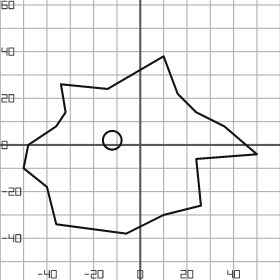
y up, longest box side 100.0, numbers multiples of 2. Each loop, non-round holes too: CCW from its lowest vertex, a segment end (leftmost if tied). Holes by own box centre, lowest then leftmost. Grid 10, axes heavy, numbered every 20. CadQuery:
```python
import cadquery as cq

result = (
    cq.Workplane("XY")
    .moveTo(-6.0, -38.0)
    .lineTo(10.0, -30.0)
    .lineTo(26.0, -26.0)
    .lineTo(24.0, -6.0)
    .lineTo(50.0, -4.0)
    .lineTo(36.0, 8.0)
    .lineTo(24.0, 14.0)
    .lineTo(16.0, 22.0)
    .lineTo(10.0, 38.0)
    .lineTo(-14.0, 24.0)
    .lineTo(-34.0, 26.0)
    .lineTo(-32.0, 14.0)
    .lineTo(-36.0, 8.0)
    .lineTo(-48.0, 0.0)
    .lineTo(-50.0, -10.0)
    .lineTo(-40.0, -18.0)
    .lineTo(-36.0, -34.0)
    .close()
    .moveTo(-12.0, 2.0)
    .circle(4.0)
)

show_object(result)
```